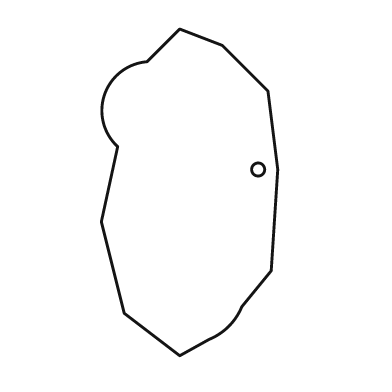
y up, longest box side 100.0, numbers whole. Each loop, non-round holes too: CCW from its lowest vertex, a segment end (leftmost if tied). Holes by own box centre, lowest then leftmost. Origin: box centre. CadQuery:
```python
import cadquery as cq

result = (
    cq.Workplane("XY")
    .moveTo(-3.0, -50.0)
    .lineTo(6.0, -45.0)
    .threePointArc((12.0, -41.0), (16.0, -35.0))
    .lineTo(25.0, -24.0)
    .lineTo(27.0, 7.0)
    .lineTo(24.0, 31.0)
    .lineTo(10.0, 45.0)
    .lineTo(-3.0, 50.0)
    .lineTo(-13.0, 40.0)
    .threePointArc((-26.0, 30.0), (-22.0, 14.0))
    .lineTo(-27.0, -9.0)
    .lineTo(-20.0, -37.0)
    .close()
    .moveTo(21.0, 7.0)
    .circle(2.0)
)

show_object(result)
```